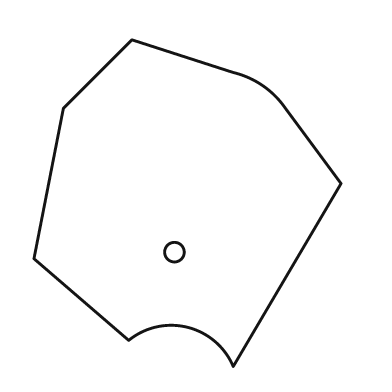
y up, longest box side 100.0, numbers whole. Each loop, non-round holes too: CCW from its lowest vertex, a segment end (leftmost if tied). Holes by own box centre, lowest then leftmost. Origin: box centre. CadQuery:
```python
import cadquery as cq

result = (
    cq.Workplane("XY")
    .moveTo(14.0, -50.0)
    .lineTo(47.0, 6.0)
    .lineTo(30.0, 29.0)
    .threePointArc((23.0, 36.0), (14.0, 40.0))
    .lineTo(-17.0, 50.0)
    .lineTo(-38.0, 29.0)
    .lineTo(-47.0, -17.0)
    .lineTo(-18.0, -42.0)
    .threePointArc((0.0, -38.0), (14.0, -50.0))
    .close()
    .moveTo(-4.0, -15.0)
    .circle(3.0)
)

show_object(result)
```